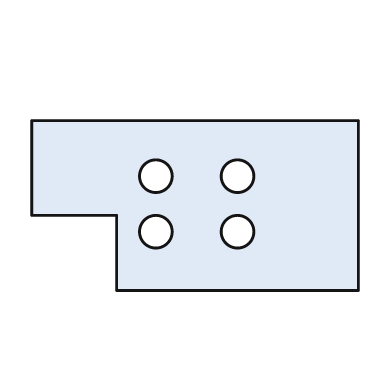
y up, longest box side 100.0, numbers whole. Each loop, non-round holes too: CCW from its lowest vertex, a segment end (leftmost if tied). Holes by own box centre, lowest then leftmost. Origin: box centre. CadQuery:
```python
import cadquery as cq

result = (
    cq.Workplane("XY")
    .moveTo(-24.0, -26.0)
    .lineTo(50.0, -26.0)
    .lineTo(50.0, 26.0)
    .lineTo(-50.0, 26.0)
    .lineTo(-50.0, -3.0)
    .lineTo(-24.0, -3.0)
    .close()
    .moveTo(-12.0, -8.0)
    .circle(5.0)
    .moveTo(13.0, -8.0)
    .circle(5.0)
    .moveTo(-12.0, 9.0)
    .circle(5.0)
    .moveTo(13.0, 9.0)
    .circle(5.0)
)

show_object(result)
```